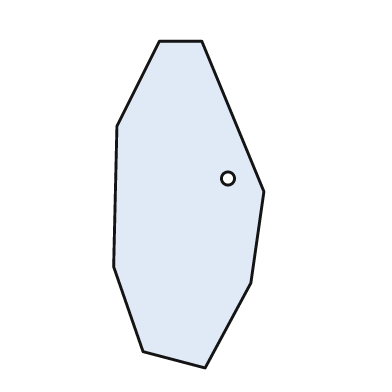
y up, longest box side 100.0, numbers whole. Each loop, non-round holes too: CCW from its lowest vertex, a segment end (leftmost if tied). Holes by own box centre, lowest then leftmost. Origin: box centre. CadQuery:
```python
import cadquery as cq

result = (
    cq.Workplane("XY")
    .moveTo(5.0, -50.0)
    .lineTo(19.0, -24.0)
    .lineTo(23.0, 4.0)
    .lineTo(4.0, 50.0)
    .lineTo(-9.0, 50.0)
    .lineTo(-22.0, 24.0)
    .lineTo(-23.0, -19.0)
    .lineTo(-14.0, -45.0)
    .close()
    .moveTo(12.0, 8.0)
    .circle(2.0)
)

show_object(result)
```